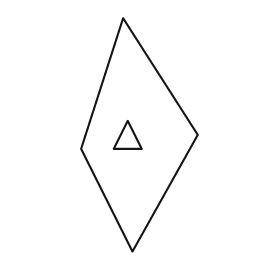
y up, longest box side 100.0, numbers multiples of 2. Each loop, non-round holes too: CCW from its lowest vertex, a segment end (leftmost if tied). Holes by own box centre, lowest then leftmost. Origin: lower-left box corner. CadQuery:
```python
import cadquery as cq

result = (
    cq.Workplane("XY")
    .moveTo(22.0, 0.0)
    .lineTo(50.0, 50.0)
    .lineTo(18.0, 100.0)
    .lineTo(0.0, 44.0)
    .close()
    .moveTo(14.0, 44.0)
    .lineTo(26.0, 44.0)
    .lineTo(20.0, 56.0)
    .close()
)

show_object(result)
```